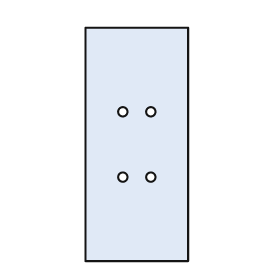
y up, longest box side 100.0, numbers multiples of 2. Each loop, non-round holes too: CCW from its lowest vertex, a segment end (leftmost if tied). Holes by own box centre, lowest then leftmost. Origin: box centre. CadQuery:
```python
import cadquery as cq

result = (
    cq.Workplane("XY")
    .moveTo(-22.0, -50.0)
    .lineTo(22.0, -50.0)
    .lineTo(22.0, 50.0)
    .lineTo(-22.0, 50.0)
    .close()
    .moveTo(-6.0, -14.0)
    .circle(2.0)
    .moveTo(6.0, -14.0)
    .circle(2.0)
    .moveTo(-6.0, 14.0)
    .circle(2.0)
    .moveTo(6.0, 14.0)
    .circle(2.0)
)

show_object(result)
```